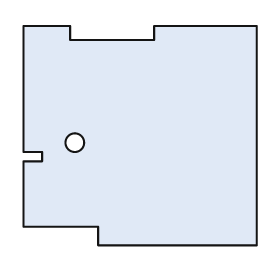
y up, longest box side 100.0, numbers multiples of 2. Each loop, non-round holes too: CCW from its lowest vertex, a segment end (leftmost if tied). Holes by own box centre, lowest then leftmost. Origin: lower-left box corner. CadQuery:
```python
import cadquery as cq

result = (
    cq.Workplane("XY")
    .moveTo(32.0, 0.0)
    .lineTo(100.0, 0.0)
    .lineTo(100.0, 94.0)
    .lineTo(56.0, 94.0)
    .lineTo(56.0, 88.0)
    .lineTo(20.0, 88.0)
    .lineTo(20.0, 94.0)
    .lineTo(0.0, 94.0)
    .lineTo(0.0, 40.0)
    .lineTo(8.0, 40.0)
    .lineTo(8.0, 36.0)
    .lineTo(0.0, 36.0)
    .lineTo(0.0, 8.0)
    .lineTo(32.0, 8.0)
    .close()
    .moveTo(22.0, 44.0)
    .circle(4.0)
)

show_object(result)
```